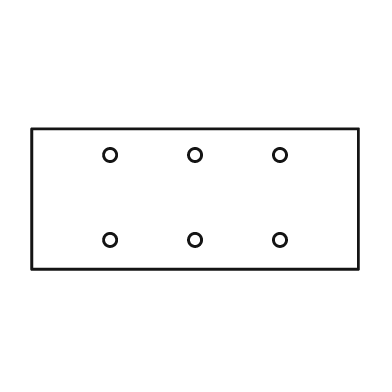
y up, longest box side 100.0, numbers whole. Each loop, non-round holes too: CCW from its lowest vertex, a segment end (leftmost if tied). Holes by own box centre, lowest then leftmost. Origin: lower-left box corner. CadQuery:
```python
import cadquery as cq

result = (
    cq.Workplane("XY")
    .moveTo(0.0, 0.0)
    .lineTo(100.0, 0.0)
    .lineTo(100.0, 43.0)
    .lineTo(0.0, 43.0)
    .close()
    .moveTo(24.0, 9.0)
    .circle(2.0)
    .moveTo(50.0, 9.0)
    .circle(2.0)
    .moveTo(76.0, 9.0)
    .circle(2.0)
    .moveTo(24.0, 35.0)
    .circle(2.0)
    .moveTo(50.0, 35.0)
    .circle(2.0)
    .moveTo(76.0, 35.0)
    .circle(2.0)
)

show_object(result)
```